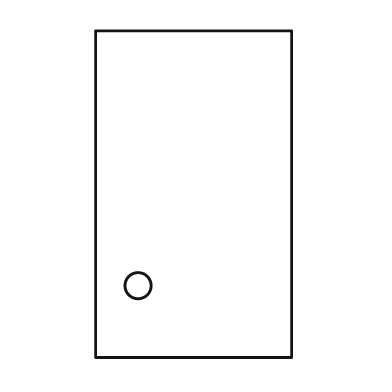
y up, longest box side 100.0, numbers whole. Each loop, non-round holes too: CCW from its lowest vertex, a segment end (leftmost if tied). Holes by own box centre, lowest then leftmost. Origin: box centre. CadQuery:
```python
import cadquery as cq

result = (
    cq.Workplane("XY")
    .moveTo(-30.0, -50.0)
    .lineTo(30.0, -50.0)
    .lineTo(30.0, 50.0)
    .lineTo(-30.0, 50.0)
    .close()
    .moveTo(-17.0, -28.0)
    .circle(4.0)
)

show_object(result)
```